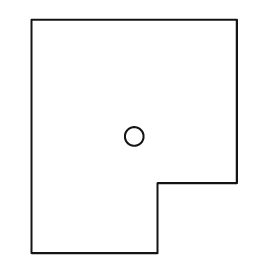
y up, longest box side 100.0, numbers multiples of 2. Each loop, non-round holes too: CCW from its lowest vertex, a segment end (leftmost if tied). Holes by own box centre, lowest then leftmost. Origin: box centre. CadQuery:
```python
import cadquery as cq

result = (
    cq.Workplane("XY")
    .moveTo(-44.0, -50.0)
    .lineTo(10.0, -50.0)
    .lineTo(10.0, -20.0)
    .lineTo(44.0, -20.0)
    .lineTo(44.0, 50.0)
    .lineTo(-44.0, 50.0)
    .close()
    .moveTo(0.0, 0.0)
    .circle(4.0)
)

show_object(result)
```